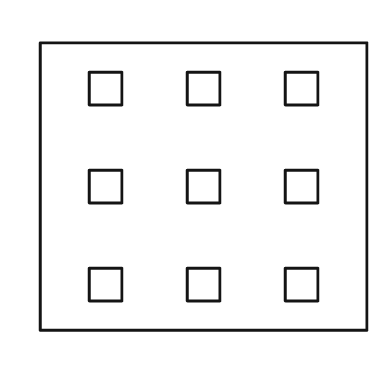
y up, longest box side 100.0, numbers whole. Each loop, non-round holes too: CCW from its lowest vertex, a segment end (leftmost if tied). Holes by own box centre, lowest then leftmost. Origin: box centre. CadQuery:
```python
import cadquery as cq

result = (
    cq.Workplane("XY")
    .moveTo(-50.0, -44.0)
    .lineTo(50.0, -44.0)
    .lineTo(50.0, 44.0)
    .lineTo(-50.0, 44.0)
    .close()
    .moveTo(-35.0, -35.0)
    .lineTo(-25.0, -35.0)
    .lineTo(-25.0, -25.0)
    .lineTo(-35.0, -25.0)
    .close()
    .moveTo(-5.0, -35.0)
    .lineTo(5.0, -35.0)
    .lineTo(5.0, -25.0)
    .lineTo(-5.0, -25.0)
    .close()
    .moveTo(25.0, -35.0)
    .lineTo(35.0, -35.0)
    .lineTo(35.0, -25.0)
    .lineTo(25.0, -25.0)
    .close()
    .moveTo(-35.0, -5.0)
    .lineTo(-25.0, -5.0)
    .lineTo(-25.0, 5.0)
    .lineTo(-35.0, 5.0)
    .close()
    .moveTo(-5.0, -5.0)
    .lineTo(5.0, -5.0)
    .lineTo(5.0, 5.0)
    .lineTo(-5.0, 5.0)
    .close()
    .moveTo(25.0, -5.0)
    .lineTo(35.0, -5.0)
    .lineTo(35.0, 5.0)
    .lineTo(25.0, 5.0)
    .close()
    .moveTo(-35.0, 25.0)
    .lineTo(-25.0, 25.0)
    .lineTo(-25.0, 35.0)
    .lineTo(-35.0, 35.0)
    .close()
    .moveTo(-5.0, 25.0)
    .lineTo(5.0, 25.0)
    .lineTo(5.0, 35.0)
    .lineTo(-5.0, 35.0)
    .close()
    .moveTo(25.0, 25.0)
    .lineTo(35.0, 25.0)
    .lineTo(35.0, 35.0)
    .lineTo(25.0, 35.0)
    .close()
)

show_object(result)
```